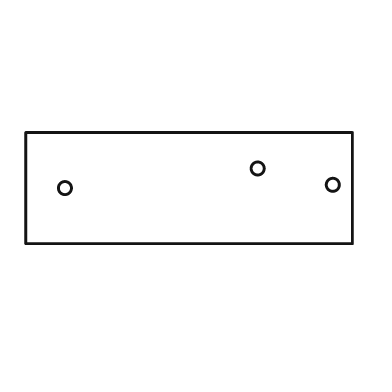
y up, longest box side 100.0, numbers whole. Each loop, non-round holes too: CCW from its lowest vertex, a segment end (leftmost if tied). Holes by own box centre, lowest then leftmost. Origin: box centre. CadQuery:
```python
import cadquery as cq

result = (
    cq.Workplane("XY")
    .moveTo(-50.0, -17.0)
    .lineTo(50.0, -17.0)
    .lineTo(50.0, 17.0)
    .lineTo(-50.0, 17.0)
    .close()
    .moveTo(-38.0, 0.0)
    .circle(2.0)
    .moveTo(44.0, 1.0)
    .circle(2.0)
    .moveTo(21.0, 6.0)
    .circle(2.0)
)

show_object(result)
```